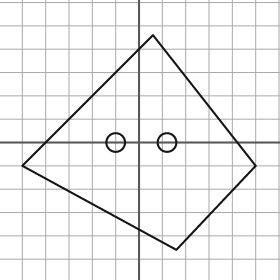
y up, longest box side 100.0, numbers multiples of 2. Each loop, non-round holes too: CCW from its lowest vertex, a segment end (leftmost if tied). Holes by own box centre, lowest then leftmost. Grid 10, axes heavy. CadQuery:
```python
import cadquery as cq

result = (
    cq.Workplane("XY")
    .moveTo(16.0, -46.0)
    .lineTo(50.0, -10.0)
    .lineTo(6.0, 46.0)
    .lineTo(-50.0, -10.0)
    .close()
    .moveTo(-10.0, 0.0)
    .circle(4.0)
    .moveTo(12.0, 0.0)
    .circle(4.0)
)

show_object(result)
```